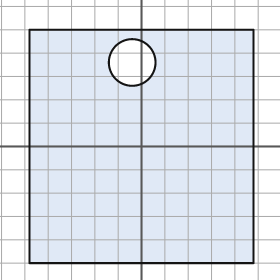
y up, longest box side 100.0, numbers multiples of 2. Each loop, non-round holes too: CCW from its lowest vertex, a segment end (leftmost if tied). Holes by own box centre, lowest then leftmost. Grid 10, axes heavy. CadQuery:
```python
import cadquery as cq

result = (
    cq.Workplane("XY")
    .moveTo(-48.0, -50.0)
    .lineTo(48.0, -50.0)
    .lineTo(48.0, 50.0)
    .lineTo(-48.0, 50.0)
    .close()
    .moveTo(-4.0, 36.0)
    .circle(10.0)
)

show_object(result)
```